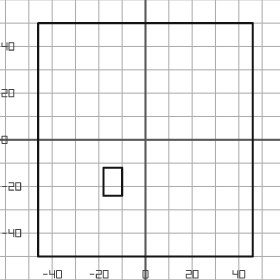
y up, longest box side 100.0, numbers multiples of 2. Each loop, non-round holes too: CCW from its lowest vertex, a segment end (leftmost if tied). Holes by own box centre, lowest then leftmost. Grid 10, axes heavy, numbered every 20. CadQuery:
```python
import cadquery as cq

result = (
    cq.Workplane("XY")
    .moveTo(-46.0, -50.0)
    .lineTo(46.0, -50.0)
    .lineTo(46.0, 50.0)
    .lineTo(-46.0, 50.0)
    .close()
    .moveTo(-18.0, -24.0)
    .lineTo(-10.0, -24.0)
    .lineTo(-10.0, -12.0)
    .lineTo(-18.0, -12.0)
    .close()
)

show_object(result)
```